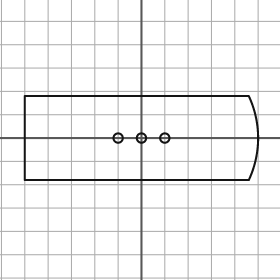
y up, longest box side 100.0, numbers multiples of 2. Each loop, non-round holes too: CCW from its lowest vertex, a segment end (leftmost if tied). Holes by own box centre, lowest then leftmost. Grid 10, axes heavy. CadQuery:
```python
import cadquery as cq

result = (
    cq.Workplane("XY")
    .moveTo(-50.0, -18.0)
    .lineTo(46.0, -18.0)
    .threePointArc((50.0, 0.0), (46.0, 18.0))
    .lineTo(-50.0, 18.0)
    .close()
    .moveTo(-10.0, 0.0)
    .circle(2.0)
    .moveTo(0.0, 0.0)
    .circle(2.0)
    .moveTo(10.0, 0.0)
    .circle(2.0)
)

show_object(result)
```